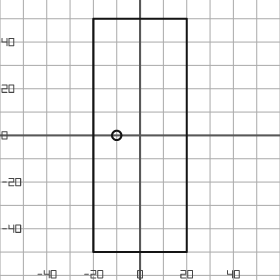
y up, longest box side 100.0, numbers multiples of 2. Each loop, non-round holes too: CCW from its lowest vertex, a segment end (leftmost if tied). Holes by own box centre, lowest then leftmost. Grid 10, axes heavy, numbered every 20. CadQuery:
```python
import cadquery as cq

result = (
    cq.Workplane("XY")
    .moveTo(-20.0, -50.0)
    .lineTo(20.0, -50.0)
    .lineTo(20.0, 50.0)
    .lineTo(-20.0, 50.0)
    .close()
    .moveTo(-10.0, 0.0)
    .circle(2.0)
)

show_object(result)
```